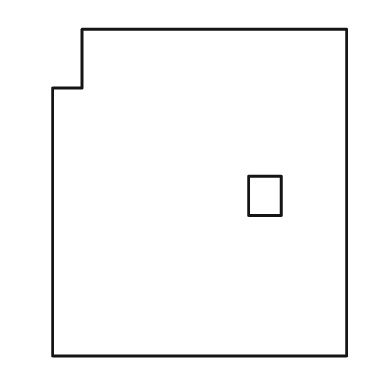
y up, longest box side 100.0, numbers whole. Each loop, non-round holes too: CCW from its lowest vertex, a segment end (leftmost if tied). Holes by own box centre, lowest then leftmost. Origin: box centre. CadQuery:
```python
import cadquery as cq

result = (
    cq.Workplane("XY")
    .moveTo(-45.0, -50.0)
    .lineTo(45.0, -50.0)
    .lineTo(45.0, 50.0)
    .lineTo(-36.0, 50.0)
    .lineTo(-36.0, 32.0)
    .lineTo(-45.0, 32.0)
    .close()
    .moveTo(15.0, -7.0)
    .lineTo(25.0, -7.0)
    .lineTo(25.0, 5.0)
    .lineTo(15.0, 5.0)
    .close()
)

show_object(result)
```